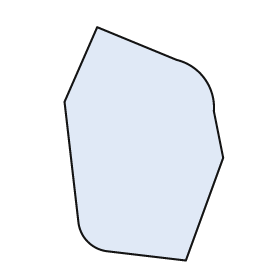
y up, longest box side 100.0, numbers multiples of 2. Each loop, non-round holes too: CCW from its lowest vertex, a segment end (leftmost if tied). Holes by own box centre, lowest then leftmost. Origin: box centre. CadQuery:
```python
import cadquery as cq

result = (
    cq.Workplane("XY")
    .moveTo(18.0, -50.0)
    .lineTo(34.0, -6.0)
    .lineTo(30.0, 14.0)
    .threePointArc((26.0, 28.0), (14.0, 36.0))
    .lineTo(-20.0, 50.0)
    .lineTo(-34.0, 18.0)
    .lineTo(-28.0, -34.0)
    .threePointArc((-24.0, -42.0), (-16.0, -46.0))
    .close()
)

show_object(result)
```